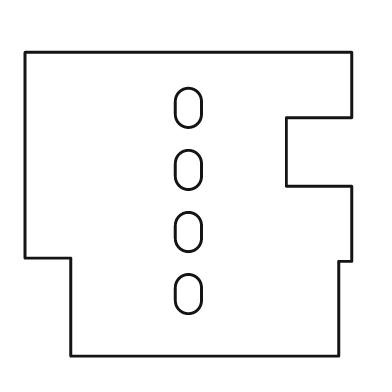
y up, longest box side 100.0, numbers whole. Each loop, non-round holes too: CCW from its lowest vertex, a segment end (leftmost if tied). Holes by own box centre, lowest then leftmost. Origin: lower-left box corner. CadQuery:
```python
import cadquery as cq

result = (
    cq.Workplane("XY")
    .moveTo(14.0, 0.0)
    .lineTo(96.0, 0.0)
    .lineTo(96.0, 29.0)
    .lineTo(100.0, 29.0)
    .lineTo(100.0, 52.0)
    .lineTo(80.0, 52.0)
    .lineTo(80.0, 73.0)
    .lineTo(100.0, 73.0)
    .lineTo(100.0, 93.0)
    .lineTo(0.0, 93.0)
    .lineTo(0.0, 30.0)
    .lineTo(14.0, 30.0)
    .close()
    .moveTo(46.0, 17.0)
    .threePointArc((50.0, 13.0), (54.0, 17.0))
    .lineTo(54.0, 21.0)
    .threePointArc((50.0, 25.0), (46.0, 21.0))
    .close()
    .moveTo(46.0, 36.0)
    .threePointArc((50.0, 32.0), (54.0, 36.0))
    .lineTo(54.0, 40.0)
    .threePointArc((50.0, 44.0), (46.0, 40.0))
    .close()
    .moveTo(46.0, 55.0)
    .threePointArc((50.0, 51.0), (54.0, 55.0))
    .lineTo(54.0, 59.0)
    .threePointArc((50.0, 63.0), (46.0, 59.0))
    .close()
    .moveTo(46.0, 74.0)
    .threePointArc((50.0, 70.0), (54.0, 74.0))
    .lineTo(54.0, 78.0)
    .threePointArc((50.0, 82.0), (46.0, 78.0))
    .close()
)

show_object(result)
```